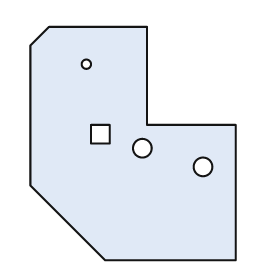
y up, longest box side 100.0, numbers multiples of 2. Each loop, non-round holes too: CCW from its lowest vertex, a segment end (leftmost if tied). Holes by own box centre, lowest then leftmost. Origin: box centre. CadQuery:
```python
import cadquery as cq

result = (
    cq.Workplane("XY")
    .moveTo(-12.0, -50.0)
    .lineTo(44.0, -50.0)
    .lineTo(44.0, 8.0)
    .lineTo(6.0, 8.0)
    .lineTo(6.0, 50.0)
    .lineTo(-36.0, 50.0)
    .lineTo(-44.0, 42.0)
    .lineTo(-44.0, -18.0)
    .close()
    .moveTo(30.0, -10.0)
    .circle(4.0)
    .moveTo(4.0, -2.0)
    .circle(4.0)
    .moveTo(-18.0, 0.0)
    .lineTo(-10.0, 0.0)
    .lineTo(-10.0, 8.0)
    .lineTo(-18.0, 8.0)
    .close()
    .moveTo(-20.0, 34.0)
    .circle(2.0)
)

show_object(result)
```